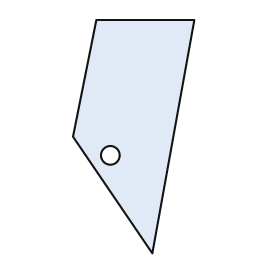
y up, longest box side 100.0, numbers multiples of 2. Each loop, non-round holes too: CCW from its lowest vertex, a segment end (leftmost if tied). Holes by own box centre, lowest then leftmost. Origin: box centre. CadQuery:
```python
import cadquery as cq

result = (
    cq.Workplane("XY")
    .moveTo(8.0, -50.0)
    .lineTo(26.0, 50.0)
    .lineTo(-16.0, 50.0)
    .lineTo(-26.0, 0.0)
    .close()
    .moveTo(-10.0, -8.0)
    .circle(4.0)
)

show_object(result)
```